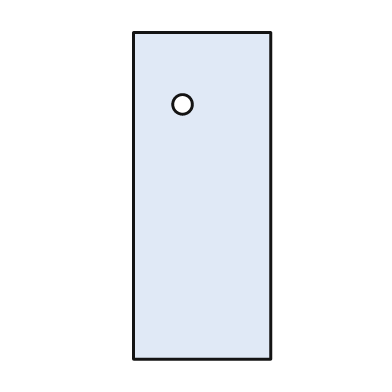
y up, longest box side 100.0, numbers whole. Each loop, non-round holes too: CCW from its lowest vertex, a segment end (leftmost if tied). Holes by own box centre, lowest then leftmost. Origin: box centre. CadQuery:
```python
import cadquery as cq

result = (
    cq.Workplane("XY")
    .moveTo(-21.0, -50.0)
    .lineTo(21.0, -50.0)
    .lineTo(21.0, 50.0)
    .lineTo(-21.0, 50.0)
    .close()
    .moveTo(-6.0, 28.0)
    .circle(3.0)
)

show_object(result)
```